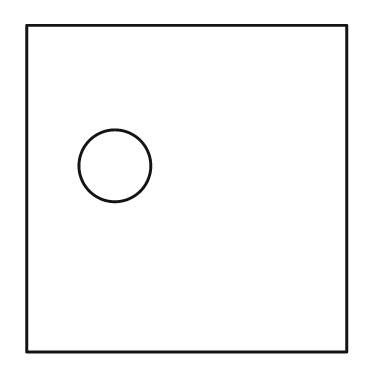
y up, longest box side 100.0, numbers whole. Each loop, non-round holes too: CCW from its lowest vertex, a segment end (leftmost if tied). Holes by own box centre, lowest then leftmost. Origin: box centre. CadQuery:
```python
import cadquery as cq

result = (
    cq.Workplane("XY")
    .moveTo(-49.0, -50.0)
    .lineTo(49.0, -50.0)
    .lineTo(49.0, 50.0)
    .lineTo(-49.0, 50.0)
    .close()
    .moveTo(-22.0, 7.0)
    .circle(11.0)
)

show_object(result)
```